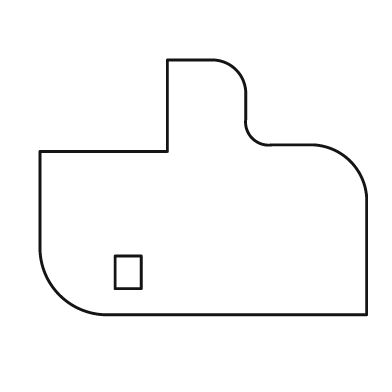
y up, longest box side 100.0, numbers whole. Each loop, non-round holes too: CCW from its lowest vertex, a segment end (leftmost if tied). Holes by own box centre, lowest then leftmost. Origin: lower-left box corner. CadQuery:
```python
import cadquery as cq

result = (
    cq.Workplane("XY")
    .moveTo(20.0, 0.0)
    .lineTo(100.0, 0.0)
    .lineTo(100.0, 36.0)
    .threePointArc((95.0, 47.0), (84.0, 52.0))
    .lineTo(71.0, 52.0)
    .threePointArc((65.0, 54.0), (63.0, 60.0))
    .lineTo(63.0, 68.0)
    .threePointArc((60.0, 75.0), (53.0, 78.0))
    .lineTo(39.0, 78.0)
    .lineTo(39.0, 50.0)
    .lineTo(0.0, 50.0)
    .lineTo(0.0, 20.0)
    .threePointArc((6.0, 6.0), (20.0, 0.0))
    .close()
    .moveTo(23.0, 8.0)
    .lineTo(31.0, 8.0)
    .lineTo(31.0, 18.0)
    .lineTo(23.0, 18.0)
    .close()
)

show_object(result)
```